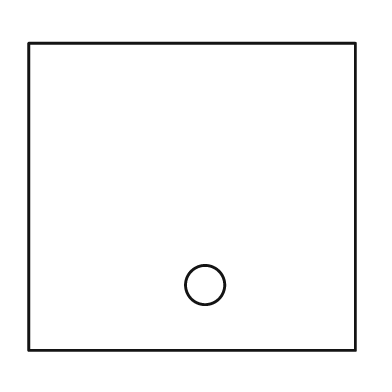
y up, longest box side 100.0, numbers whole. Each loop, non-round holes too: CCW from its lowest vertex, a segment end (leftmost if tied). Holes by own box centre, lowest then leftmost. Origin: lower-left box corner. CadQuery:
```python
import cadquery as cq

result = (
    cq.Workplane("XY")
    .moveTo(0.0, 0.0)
    .lineTo(100.0, 0.0)
    .lineTo(100.0, 94.0)
    .lineTo(0.0, 94.0)
    .close()
    .moveTo(54.0, 20.0)
    .circle(6.0)
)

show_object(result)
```